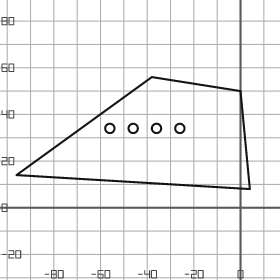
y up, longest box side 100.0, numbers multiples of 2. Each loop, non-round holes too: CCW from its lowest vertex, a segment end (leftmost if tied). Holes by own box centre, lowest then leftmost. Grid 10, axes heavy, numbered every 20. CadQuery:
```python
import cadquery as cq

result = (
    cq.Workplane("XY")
    .moveTo(4.0, 8.0)
    .lineTo(0.0, 50.0)
    .lineTo(-38.0, 56.0)
    .lineTo(-96.0, 14.0)
    .close()
    .moveTo(-56.0, 34.0)
    .circle(2.0)
    .moveTo(-46.0, 34.0)
    .circle(2.0)
    .moveTo(-36.0, 34.0)
    .circle(2.0)
    .moveTo(-26.0, 34.0)
    .circle(2.0)
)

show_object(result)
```